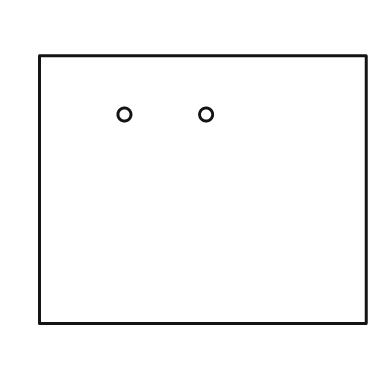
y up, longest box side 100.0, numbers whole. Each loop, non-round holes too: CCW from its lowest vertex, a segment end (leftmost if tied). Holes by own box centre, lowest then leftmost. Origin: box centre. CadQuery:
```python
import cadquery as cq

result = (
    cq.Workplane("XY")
    .moveTo(-50.0, -41.0)
    .lineTo(50.0, -41.0)
    .lineTo(50.0, 41.0)
    .lineTo(-50.0, 41.0)
    .close()
    .moveTo(-24.0, 23.0)
    .circle(2.0)
    .moveTo(1.0, 23.0)
    .circle(2.0)
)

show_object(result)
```